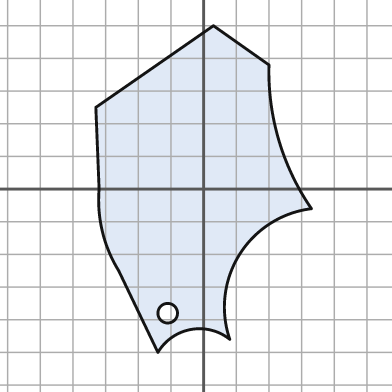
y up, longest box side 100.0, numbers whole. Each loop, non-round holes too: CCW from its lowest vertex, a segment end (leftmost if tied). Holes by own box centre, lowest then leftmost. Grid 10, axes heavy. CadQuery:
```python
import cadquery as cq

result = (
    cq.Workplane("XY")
    .moveTo(-14.0, -50.0)
    .threePointArc((-4.0, -43.0), (8.0, -46.0))
    .threePointArc((11.0, -20.0), (33.0, -6.0))
    .threePointArc((23.0, 15.0), (20.0, 38.0))
    .lineTo(3.0, 50.0)
    .lineTo(-33.0, 25.0)
    .lineTo(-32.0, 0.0)
    .threePointArc((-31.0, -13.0), (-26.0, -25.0))
    .close()
    .moveTo(-11.0, -38.0)
    .circle(3.0)
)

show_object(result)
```